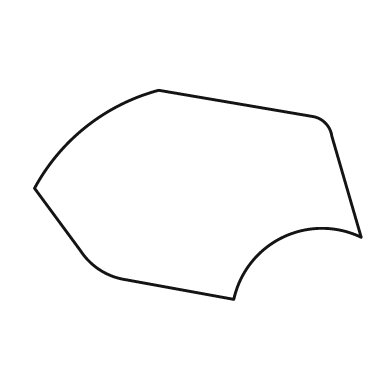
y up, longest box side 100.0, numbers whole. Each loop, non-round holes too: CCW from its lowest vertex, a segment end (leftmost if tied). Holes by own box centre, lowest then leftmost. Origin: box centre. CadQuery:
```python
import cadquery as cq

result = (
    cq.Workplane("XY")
    .moveTo(11.0, -32.0)
    .threePointArc((26.0, -13.0), (50.0, -13.0))
    .lineTo(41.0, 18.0)
    .threePointArc((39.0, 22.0), (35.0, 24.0))
    .lineTo(-12.0, 32.0)
    .threePointArc((-34.0, 21.0), (-50.0, 2.0))
    .lineTo(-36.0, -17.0)
    .threePointArc((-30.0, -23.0), (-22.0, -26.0))
    .close()
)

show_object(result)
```